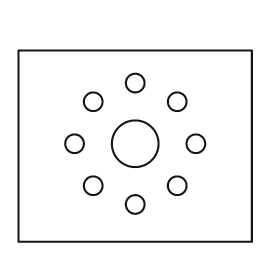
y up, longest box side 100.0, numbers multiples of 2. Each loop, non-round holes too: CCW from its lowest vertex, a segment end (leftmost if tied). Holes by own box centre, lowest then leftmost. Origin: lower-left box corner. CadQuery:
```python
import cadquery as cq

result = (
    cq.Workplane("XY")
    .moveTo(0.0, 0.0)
    .lineTo(100.0, 0.0)
    .lineTo(100.0, 82.0)
    .lineTo(0.0, 82.0)
    .close()
    .moveTo(50.0, 16.0)
    .circle(4.0)
    .moveTo(32.0, 24.0)
    .circle(4.0)
    .moveTo(68.0, 24.0)
    .circle(4.0)
    .moveTo(24.0, 42.0)
    .circle(4.0)
    .moveTo(50.0, 42.0)
    .circle(10.0)
    .moveTo(76.0, 42.0)
    .circle(4.0)
    .moveTo(32.0, 60.0)
    .circle(4.0)
    .moveTo(68.0, 60.0)
    .circle(4.0)
    .moveTo(50.0, 68.0)
    .circle(4.0)
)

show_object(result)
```